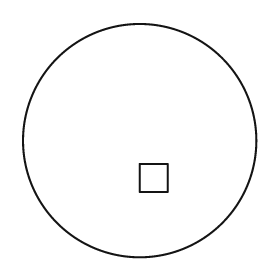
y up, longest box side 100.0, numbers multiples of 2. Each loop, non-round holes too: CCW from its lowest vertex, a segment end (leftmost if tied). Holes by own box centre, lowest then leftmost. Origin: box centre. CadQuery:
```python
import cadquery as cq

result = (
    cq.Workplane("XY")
    .moveTo(0.0, 0.0)
    .circle(50.0)
    .moveTo(0.0, -22.0)
    .lineTo(12.0, -22.0)
    .lineTo(12.0, -10.0)
    .lineTo(0.0, -10.0)
    .close()
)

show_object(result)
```